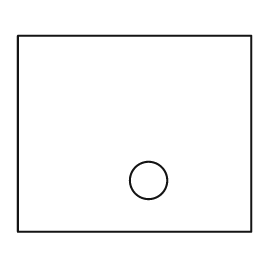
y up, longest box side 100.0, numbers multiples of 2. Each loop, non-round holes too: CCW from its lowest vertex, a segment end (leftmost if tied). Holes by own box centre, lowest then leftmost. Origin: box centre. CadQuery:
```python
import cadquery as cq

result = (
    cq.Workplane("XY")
    .moveTo(-50.0, -42.0)
    .lineTo(50.0, -42.0)
    .lineTo(50.0, 42.0)
    .lineTo(-50.0, 42.0)
    .close()
    .moveTo(6.0, -20.0)
    .circle(8.0)
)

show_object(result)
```